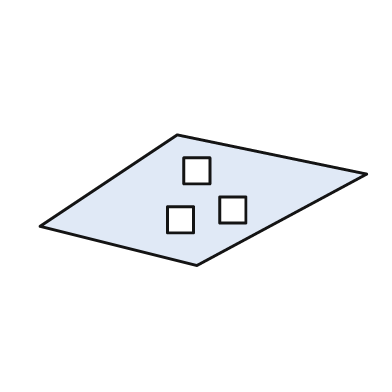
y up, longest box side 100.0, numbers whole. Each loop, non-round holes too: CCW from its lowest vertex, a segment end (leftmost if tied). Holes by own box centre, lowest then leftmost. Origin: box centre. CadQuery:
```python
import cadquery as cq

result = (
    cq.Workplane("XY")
    .moveTo(-2.0, -20.0)
    .lineTo(50.0, 8.0)
    .lineTo(-8.0, 20.0)
    .lineTo(-50.0, -8.0)
    .close()
    .moveTo(-11.0, -10.0)
    .lineTo(-3.0, -10.0)
    .lineTo(-3.0, -2.0)
    .lineTo(-11.0, -2.0)
    .close()
    .moveTo(5.0, -7.0)
    .lineTo(13.0, -7.0)
    .lineTo(13.0, 1.0)
    .lineTo(5.0, 1.0)
    .close()
    .moveTo(-6.0, 5.0)
    .lineTo(2.0, 5.0)
    .lineTo(2.0, 13.0)
    .lineTo(-6.0, 13.0)
    .close()
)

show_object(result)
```